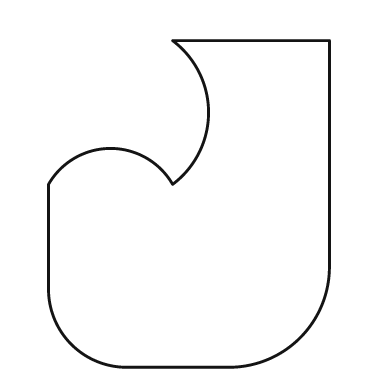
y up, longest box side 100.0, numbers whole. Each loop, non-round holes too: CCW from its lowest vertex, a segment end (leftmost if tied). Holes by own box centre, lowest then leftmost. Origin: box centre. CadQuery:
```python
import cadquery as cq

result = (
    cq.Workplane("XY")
    .moveTo(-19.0, -50.0)
    .lineTo(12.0, -50.0)
    .threePointArc((34.0, -41.0), (43.0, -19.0))
    .lineTo(43.0, 50.0)
    .lineTo(-5.0, 50.0)
    .threePointArc((6.0, 28.0), (-5.0, 6.0))
    .threePointArc((-24.0, 17.0), (-43.0, 6.0))
    .lineTo(-43.0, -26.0)
    .threePointArc((-36.0, -43.0), (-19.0, -50.0))
    .close()
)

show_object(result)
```